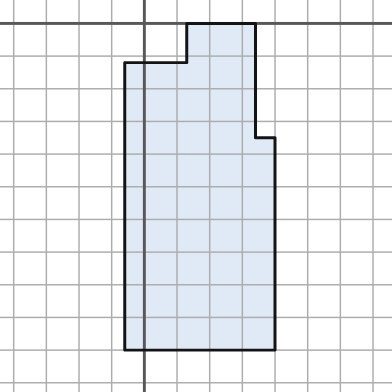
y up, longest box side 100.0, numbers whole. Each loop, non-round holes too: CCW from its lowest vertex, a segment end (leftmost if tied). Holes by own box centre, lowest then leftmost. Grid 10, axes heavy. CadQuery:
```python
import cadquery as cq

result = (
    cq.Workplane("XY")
    .moveTo(-6.0, -100.0)
    .lineTo(40.0, -100.0)
    .lineTo(40.0, -35.0)
    .lineTo(34.0, -35.0)
    .lineTo(34.0, 0.0)
    .lineTo(13.0, 0.0)
    .lineTo(13.0, -12.0)
    .lineTo(-6.0, -12.0)
    .close()
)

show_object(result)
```